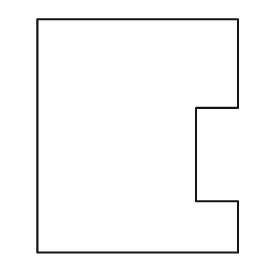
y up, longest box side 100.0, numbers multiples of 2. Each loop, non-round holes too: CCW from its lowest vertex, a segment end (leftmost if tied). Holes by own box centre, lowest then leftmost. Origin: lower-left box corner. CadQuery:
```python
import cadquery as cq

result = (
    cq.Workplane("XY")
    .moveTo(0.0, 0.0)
    .lineTo(86.0, 0.0)
    .lineTo(86.0, 22.0)
    .lineTo(68.0, 22.0)
    .lineTo(68.0, 62.0)
    .lineTo(86.0, 62.0)
    .lineTo(86.0, 100.0)
    .lineTo(0.0, 100.0)
    .close()
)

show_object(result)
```